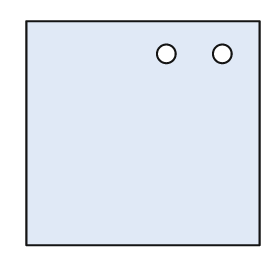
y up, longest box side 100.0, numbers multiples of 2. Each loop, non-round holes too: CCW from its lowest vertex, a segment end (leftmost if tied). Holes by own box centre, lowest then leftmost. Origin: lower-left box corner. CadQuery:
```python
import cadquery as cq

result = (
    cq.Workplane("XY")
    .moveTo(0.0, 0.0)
    .lineTo(100.0, 0.0)
    .lineTo(100.0, 96.0)
    .lineTo(0.0, 96.0)
    .close()
    .moveTo(60.0, 82.0)
    .circle(4.0)
    .moveTo(84.0, 82.0)
    .circle(4.0)
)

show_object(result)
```